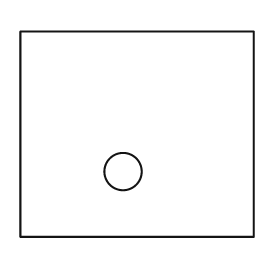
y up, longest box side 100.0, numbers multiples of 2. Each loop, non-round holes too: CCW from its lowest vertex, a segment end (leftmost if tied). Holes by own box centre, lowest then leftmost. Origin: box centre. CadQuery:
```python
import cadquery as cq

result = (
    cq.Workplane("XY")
    .moveTo(-50.0, -44.0)
    .lineTo(50.0, -44.0)
    .lineTo(50.0, 44.0)
    .lineTo(-50.0, 44.0)
    .close()
    .moveTo(-6.0, -16.0)
    .circle(8.0)
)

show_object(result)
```